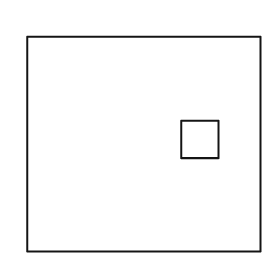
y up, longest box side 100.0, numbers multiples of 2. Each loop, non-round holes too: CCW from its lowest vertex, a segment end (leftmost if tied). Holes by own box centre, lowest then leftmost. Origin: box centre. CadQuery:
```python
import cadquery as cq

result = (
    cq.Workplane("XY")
    .moveTo(-50.0, -46.0)
    .lineTo(50.0, -46.0)
    .lineTo(50.0, 46.0)
    .lineTo(-50.0, 46.0)
    .close()
    .moveTo(16.0, -6.0)
    .lineTo(32.0, -6.0)
    .lineTo(32.0, 10.0)
    .lineTo(16.0, 10.0)
    .close()
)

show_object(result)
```